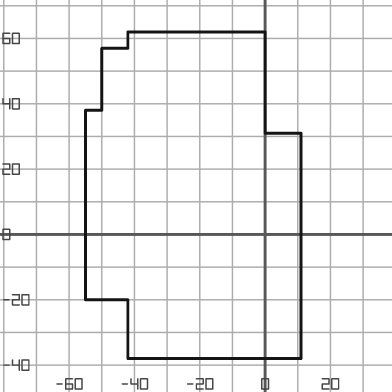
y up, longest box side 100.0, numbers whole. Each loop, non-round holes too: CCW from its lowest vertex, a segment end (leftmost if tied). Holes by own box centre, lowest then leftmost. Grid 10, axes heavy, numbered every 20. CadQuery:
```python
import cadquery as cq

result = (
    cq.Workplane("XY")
    .moveTo(-42.0, -38.0)
    .lineTo(11.0, -38.0)
    .lineTo(11.0, 31.0)
    .lineTo(0.0, 31.0)
    .lineTo(0.0, 62.0)
    .lineTo(-42.0, 62.0)
    .lineTo(-42.0, 57.0)
    .lineTo(-50.0, 57.0)
    .lineTo(-50.0, 38.0)
    .lineTo(-55.0, 38.0)
    .lineTo(-55.0, -20.0)
    .lineTo(-42.0, -20.0)
    .close()
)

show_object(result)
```